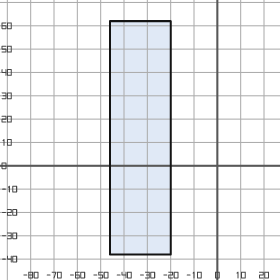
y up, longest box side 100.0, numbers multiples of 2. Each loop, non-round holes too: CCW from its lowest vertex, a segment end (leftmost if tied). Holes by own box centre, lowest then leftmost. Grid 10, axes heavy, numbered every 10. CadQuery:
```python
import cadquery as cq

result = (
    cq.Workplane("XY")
    .moveTo(-46.0, -38.0)
    .lineTo(-20.0, -38.0)
    .lineTo(-20.0, 62.0)
    .lineTo(-46.0, 62.0)
    .close()
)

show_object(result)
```